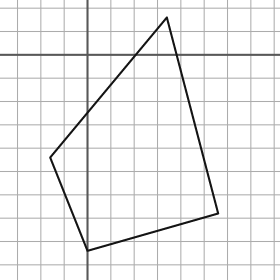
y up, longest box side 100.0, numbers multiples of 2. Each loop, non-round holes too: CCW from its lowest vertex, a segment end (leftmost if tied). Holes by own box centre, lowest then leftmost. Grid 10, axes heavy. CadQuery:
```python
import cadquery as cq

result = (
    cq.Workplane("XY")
    .moveTo(0.0, -84.0)
    .lineTo(56.0, -68.0)
    .lineTo(34.0, 16.0)
    .lineTo(-16.0, -44.0)
    .close()
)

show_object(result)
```